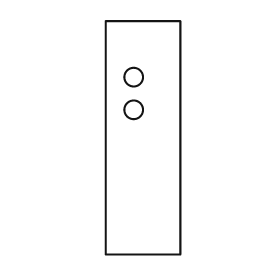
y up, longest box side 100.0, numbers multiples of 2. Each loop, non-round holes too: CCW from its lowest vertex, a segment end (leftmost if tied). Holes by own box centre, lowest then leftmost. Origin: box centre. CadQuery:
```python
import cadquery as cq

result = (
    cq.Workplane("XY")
    .moveTo(-16.0, -50.0)
    .lineTo(16.0, -50.0)
    .lineTo(16.0, 50.0)
    .lineTo(-16.0, 50.0)
    .close()
    .moveTo(-4.0, 12.0)
    .circle(4.0)
    .moveTo(-4.0, 26.0)
    .circle(4.0)
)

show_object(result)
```